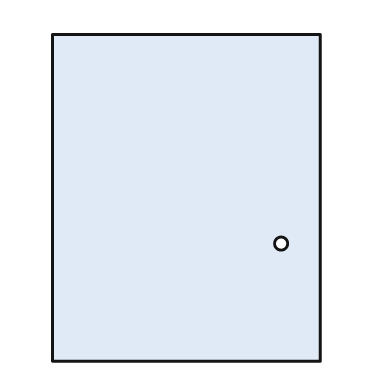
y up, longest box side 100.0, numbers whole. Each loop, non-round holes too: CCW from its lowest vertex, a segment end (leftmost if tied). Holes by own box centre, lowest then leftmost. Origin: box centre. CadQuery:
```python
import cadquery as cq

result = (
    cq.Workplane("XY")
    .moveTo(-41.0, -50.0)
    .lineTo(41.0, -50.0)
    .lineTo(41.0, 50.0)
    .lineTo(-41.0, 50.0)
    .close()
    .moveTo(29.0, -14.0)
    .circle(2.0)
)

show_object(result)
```